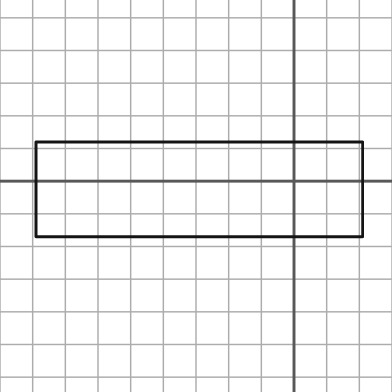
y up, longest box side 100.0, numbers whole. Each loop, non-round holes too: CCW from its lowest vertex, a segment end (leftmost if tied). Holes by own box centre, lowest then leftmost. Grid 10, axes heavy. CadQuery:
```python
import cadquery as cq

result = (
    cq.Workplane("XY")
    .moveTo(-79.0, -17.0)
    .lineTo(21.0, -17.0)
    .lineTo(21.0, 12.0)
    .lineTo(-79.0, 12.0)
    .close()
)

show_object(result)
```